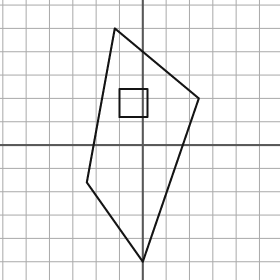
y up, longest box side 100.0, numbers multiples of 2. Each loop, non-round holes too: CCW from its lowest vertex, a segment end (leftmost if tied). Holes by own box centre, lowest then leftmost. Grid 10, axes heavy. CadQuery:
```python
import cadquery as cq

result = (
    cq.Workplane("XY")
    .moveTo(0.0, -50.0)
    .lineTo(24.0, 20.0)
    .lineTo(-12.0, 50.0)
    .lineTo(-24.0, -16.0)
    .close()
    .moveTo(-10.0, 12.0)
    .lineTo(2.0, 12.0)
    .lineTo(2.0, 24.0)
    .lineTo(-10.0, 24.0)
    .close()
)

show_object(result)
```